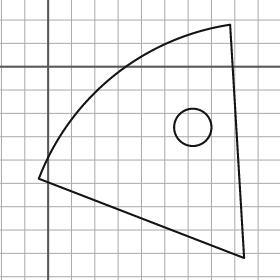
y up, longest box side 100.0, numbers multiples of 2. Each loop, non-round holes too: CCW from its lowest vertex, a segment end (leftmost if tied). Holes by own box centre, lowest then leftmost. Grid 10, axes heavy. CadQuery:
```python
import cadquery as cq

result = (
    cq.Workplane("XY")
    .moveTo(84.0, -82.0)
    .lineTo(78.0, 18.0)
    .threePointArc((28.0, -4.0), (-4.0, -48.0))
    .close()
    .moveTo(62.0, -26.0)
    .circle(8.0)
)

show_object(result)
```